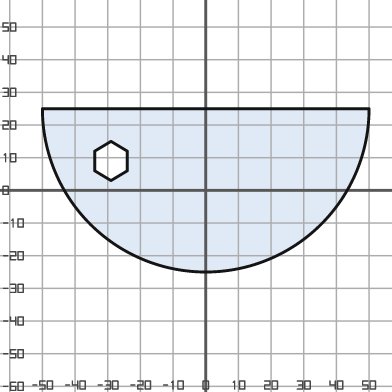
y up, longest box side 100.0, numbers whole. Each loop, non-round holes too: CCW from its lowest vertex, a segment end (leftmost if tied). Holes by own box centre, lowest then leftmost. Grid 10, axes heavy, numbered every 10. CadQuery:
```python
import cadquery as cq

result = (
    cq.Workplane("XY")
    .moveTo(-50.0, 25.0)
    .threePointArc((0.0, -25.0), (50.0, 25.0))
    .close()
    .moveTo(-29.0, 3.0)
    .lineTo(-24.0, 6.0)
    .lineTo(-24.0, 12.0)
    .lineTo(-29.0, 15.0)
    .lineTo(-34.0, 12.0)
    .lineTo(-34.0, 6.0)
    .close()
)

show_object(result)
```